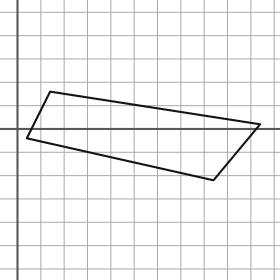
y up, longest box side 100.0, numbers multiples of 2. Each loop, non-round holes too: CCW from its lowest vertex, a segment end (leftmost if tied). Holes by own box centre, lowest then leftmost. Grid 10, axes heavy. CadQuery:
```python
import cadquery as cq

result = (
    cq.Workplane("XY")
    .moveTo(84.0, -22.0)
    .lineTo(104.0, 2.0)
    .lineTo(14.0, 16.0)
    .lineTo(4.0, -4.0)
    .close()
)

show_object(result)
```